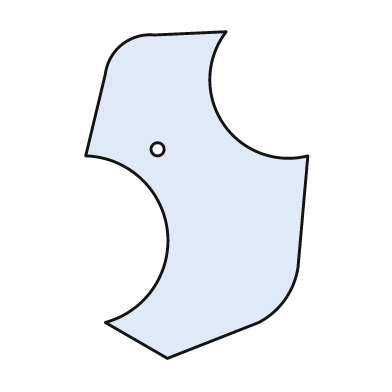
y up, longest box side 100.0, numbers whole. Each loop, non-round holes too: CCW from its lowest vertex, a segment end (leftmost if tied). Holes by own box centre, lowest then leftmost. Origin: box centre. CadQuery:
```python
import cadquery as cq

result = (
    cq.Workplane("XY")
    .moveTo(-9.0, -50.0)
    .lineTo(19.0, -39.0)
    .threePointArc((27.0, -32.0), (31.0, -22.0))
    .lineTo(34.0, 12.0)
    .threePointArc((8.0, 22.0), (9.0, 50.0))
    .lineTo(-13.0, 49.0)
    .threePointArc((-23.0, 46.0), (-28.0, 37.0))
    .lineTo(-34.0, 12.0)
    .threePointArc((-9.0, -11.0), (-28.0, -39.0))
    .close()
    .moveTo(-12.0, 14.0)
    .circle(2.0)
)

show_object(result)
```